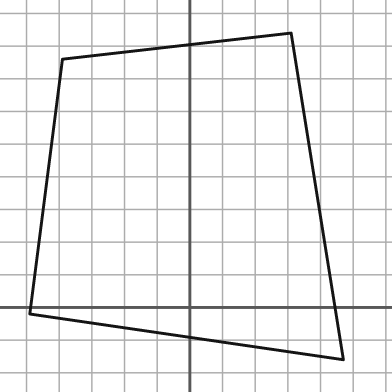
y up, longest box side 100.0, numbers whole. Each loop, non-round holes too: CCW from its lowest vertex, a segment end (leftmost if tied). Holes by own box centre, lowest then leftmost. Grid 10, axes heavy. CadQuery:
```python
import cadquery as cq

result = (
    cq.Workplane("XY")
    .moveTo(47.0, -16.0)
    .lineTo(31.0, 84.0)
    .lineTo(-39.0, 76.0)
    .lineTo(-49.0, -2.0)
    .close()
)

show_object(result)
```